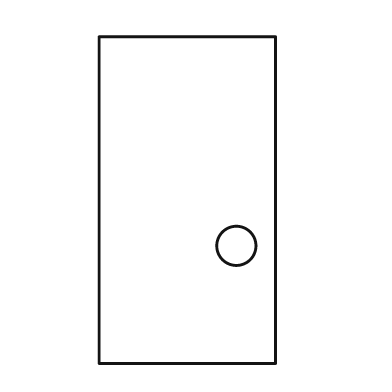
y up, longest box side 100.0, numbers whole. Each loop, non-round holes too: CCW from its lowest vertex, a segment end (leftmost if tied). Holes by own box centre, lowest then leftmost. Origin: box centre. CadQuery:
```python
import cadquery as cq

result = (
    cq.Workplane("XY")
    .moveTo(-27.0, -50.0)
    .lineTo(27.0, -50.0)
    .lineTo(27.0, 50.0)
    .lineTo(-27.0, 50.0)
    .close()
    .moveTo(15.0, -14.0)
    .circle(6.0)
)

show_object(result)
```